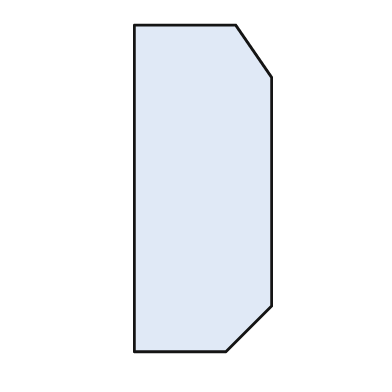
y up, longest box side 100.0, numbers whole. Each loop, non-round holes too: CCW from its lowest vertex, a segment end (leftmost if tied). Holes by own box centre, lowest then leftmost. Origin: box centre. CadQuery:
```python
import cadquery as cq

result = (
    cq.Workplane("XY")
    .moveTo(-21.0, -50.0)
    .lineTo(7.0, -50.0)
    .lineTo(21.0, -36.0)
    .lineTo(21.0, 34.0)
    .lineTo(10.0, 50.0)
    .lineTo(-21.0, 50.0)
    .close()
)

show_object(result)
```